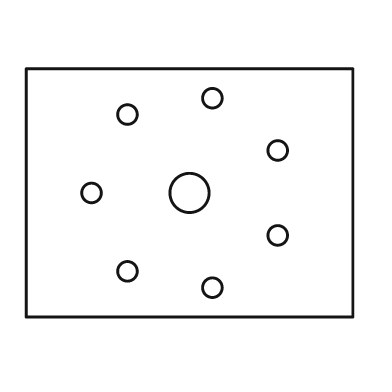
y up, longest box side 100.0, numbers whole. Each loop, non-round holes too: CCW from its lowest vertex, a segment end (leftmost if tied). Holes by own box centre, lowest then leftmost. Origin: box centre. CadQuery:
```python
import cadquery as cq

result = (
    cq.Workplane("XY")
    .moveTo(-50.0, -38.0)
    .lineTo(50.0, -38.0)
    .lineTo(50.0, 38.0)
    .lineTo(-50.0, 38.0)
    .close()
    .moveTo(7.0, -29.0)
    .circle(3.0)
    .moveTo(-19.0, -24.0)
    .circle(3.0)
    .moveTo(27.0, -13.0)
    .circle(3.0)
    .moveTo(-30.0, 0.0)
    .circle(3.0)
    .moveTo(0.0, 0.0)
    .circle(6.0)
    .moveTo(27.0, 13.0)
    .circle(3.0)
    .moveTo(-19.0, 24.0)
    .circle(3.0)
    .moveTo(7.0, 29.0)
    .circle(3.0)
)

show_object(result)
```